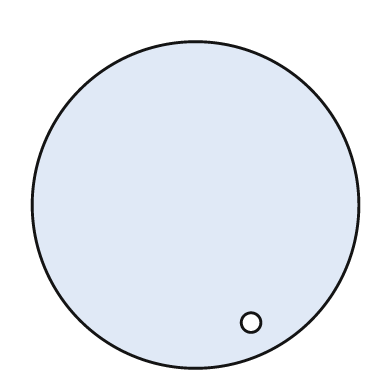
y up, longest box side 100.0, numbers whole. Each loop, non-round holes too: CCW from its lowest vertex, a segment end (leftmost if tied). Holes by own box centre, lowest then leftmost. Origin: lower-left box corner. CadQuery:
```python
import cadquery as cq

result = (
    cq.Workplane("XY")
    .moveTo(50.0, 50.0)
    .circle(50.0)
    .moveTo(67.0, 14.0)
    .circle(3.0)
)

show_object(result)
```